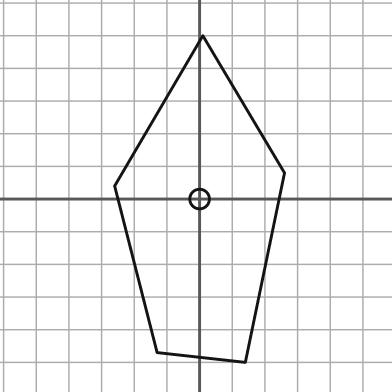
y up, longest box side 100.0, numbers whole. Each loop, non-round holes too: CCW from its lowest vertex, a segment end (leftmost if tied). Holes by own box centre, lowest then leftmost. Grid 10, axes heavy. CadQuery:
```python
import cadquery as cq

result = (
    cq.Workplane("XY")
    .moveTo(14.0, -50.0)
    .lineTo(26.0, 8.0)
    .lineTo(1.0, 50.0)
    .lineTo(-26.0, 4.0)
    .lineTo(-13.0, -47.0)
    .close()
    .moveTo(0.0, 0.0)
    .circle(3.0)
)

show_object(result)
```